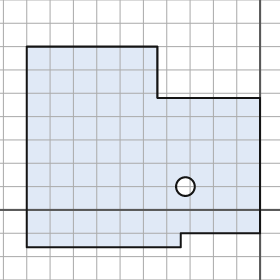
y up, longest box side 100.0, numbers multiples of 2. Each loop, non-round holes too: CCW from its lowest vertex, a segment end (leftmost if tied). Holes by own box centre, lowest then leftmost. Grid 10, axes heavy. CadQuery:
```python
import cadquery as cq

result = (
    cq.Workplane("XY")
    .moveTo(-100.0, -16.0)
    .lineTo(-34.0, -16.0)
    .lineTo(-34.0, -10.0)
    .lineTo(0.0, -10.0)
    .lineTo(0.0, 48.0)
    .lineTo(-44.0, 48.0)
    .lineTo(-44.0, 70.0)
    .lineTo(-100.0, 70.0)
    .close()
    .moveTo(-32.0, 10.0)
    .circle(4.0)
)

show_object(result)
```